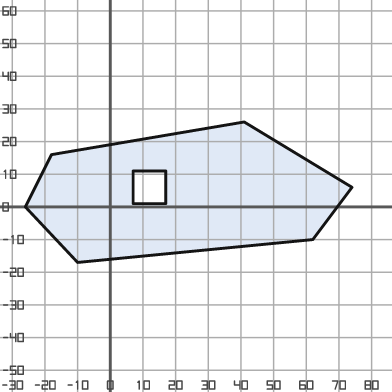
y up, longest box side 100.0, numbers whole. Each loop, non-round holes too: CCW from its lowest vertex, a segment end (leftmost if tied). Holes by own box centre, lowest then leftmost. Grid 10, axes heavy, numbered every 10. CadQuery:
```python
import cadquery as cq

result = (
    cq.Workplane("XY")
    .moveTo(-10.0, -17.0)
    .lineTo(62.0, -10.0)
    .lineTo(74.0, 6.0)
    .lineTo(41.0, 26.0)
    .lineTo(-18.0, 16.0)
    .lineTo(-26.0, 0.0)
    .close()
    .moveTo(7.0, 1.0)
    .lineTo(17.0, 1.0)
    .lineTo(17.0, 11.0)
    .lineTo(7.0, 11.0)
    .close()
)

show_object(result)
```